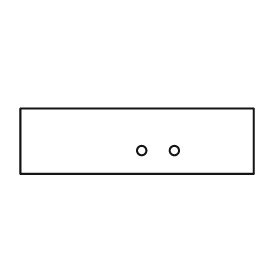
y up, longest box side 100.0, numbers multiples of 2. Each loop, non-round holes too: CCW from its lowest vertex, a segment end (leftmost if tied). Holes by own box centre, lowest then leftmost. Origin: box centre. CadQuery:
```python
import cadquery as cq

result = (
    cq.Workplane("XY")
    .moveTo(-50.0, -14.0)
    .lineTo(50.0, -14.0)
    .lineTo(50.0, 14.0)
    .lineTo(-50.0, 14.0)
    .close()
    .moveTo(2.0, -4.0)
    .circle(2.0)
    .moveTo(16.0, -4.0)
    .circle(2.0)
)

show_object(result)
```